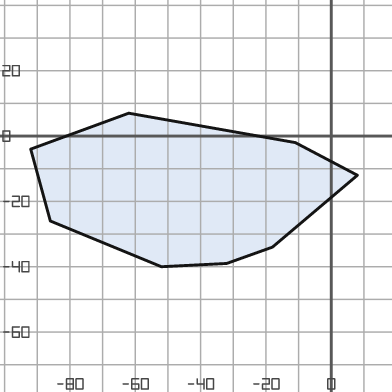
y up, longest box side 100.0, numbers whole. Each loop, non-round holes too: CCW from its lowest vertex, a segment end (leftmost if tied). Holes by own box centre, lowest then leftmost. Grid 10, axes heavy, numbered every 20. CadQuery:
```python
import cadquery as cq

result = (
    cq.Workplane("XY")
    .moveTo(-52.0, -40.0)
    .lineTo(-32.0, -39.0)
    .lineTo(-18.0, -34.0)
    .lineTo(8.0, -12.0)
    .lineTo(-11.0, -2.0)
    .lineTo(-62.0, 7.0)
    .lineTo(-92.0, -4.0)
    .lineTo(-86.0, -26.0)
    .close()
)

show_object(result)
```